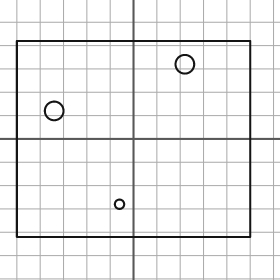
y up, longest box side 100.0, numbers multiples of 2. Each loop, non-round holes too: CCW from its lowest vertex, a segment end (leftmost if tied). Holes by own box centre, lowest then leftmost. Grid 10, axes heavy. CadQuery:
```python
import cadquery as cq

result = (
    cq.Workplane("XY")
    .moveTo(-50.0, -42.0)
    .lineTo(50.0, -42.0)
    .lineTo(50.0, 42.0)
    .lineTo(-50.0, 42.0)
    .close()
    .moveTo(-6.0, -28.0)
    .circle(2.0)
    .moveTo(-34.0, 12.0)
    .circle(4.0)
    .moveTo(22.0, 32.0)
    .circle(4.0)
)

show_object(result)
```